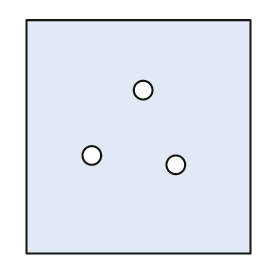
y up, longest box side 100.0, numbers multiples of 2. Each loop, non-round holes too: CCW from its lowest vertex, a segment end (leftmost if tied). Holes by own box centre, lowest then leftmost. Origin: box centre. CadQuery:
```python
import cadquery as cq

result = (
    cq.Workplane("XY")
    .moveTo(-48.0, -50.0)
    .lineTo(48.0, -50.0)
    .lineTo(48.0, 50.0)
    .lineTo(-48.0, 50.0)
    .close()
    .moveTo(16.0, -12.0)
    .circle(4.0)
    .moveTo(-20.0, -8.0)
    .circle(4.0)
    .moveTo(2.0, 20.0)
    .circle(4.0)
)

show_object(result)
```